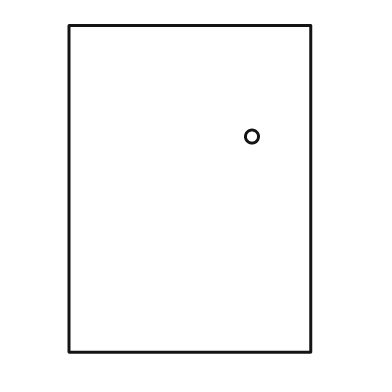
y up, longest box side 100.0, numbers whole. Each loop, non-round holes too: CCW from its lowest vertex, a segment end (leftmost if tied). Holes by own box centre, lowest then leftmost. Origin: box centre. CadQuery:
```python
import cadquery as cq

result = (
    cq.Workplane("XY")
    .moveTo(-37.0, -50.0)
    .lineTo(37.0, -50.0)
    .lineTo(37.0, 50.0)
    .lineTo(-37.0, 50.0)
    .close()
    .moveTo(19.0, 16.0)
    .circle(2.0)
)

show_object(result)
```